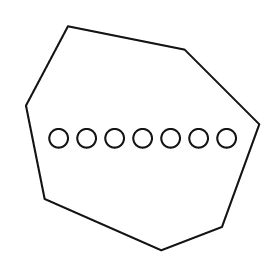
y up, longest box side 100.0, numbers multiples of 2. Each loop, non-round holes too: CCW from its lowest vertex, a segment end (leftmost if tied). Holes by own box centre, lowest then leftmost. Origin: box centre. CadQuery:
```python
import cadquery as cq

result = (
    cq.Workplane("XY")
    .moveTo(8.0, -48.0)
    .lineTo(34.0, -38.0)
    .lineTo(50.0, 6.0)
    .lineTo(18.0, 38.0)
    .lineTo(-32.0, 48.0)
    .lineTo(-50.0, 14.0)
    .lineTo(-42.0, -26.0)
    .close()
    .moveTo(-36.0, 0.0)
    .circle(4.0)
    .moveTo(-24.0, 0.0)
    .circle(4.0)
    .moveTo(-12.0, 0.0)
    .circle(4.0)
    .moveTo(0.0, 0.0)
    .circle(4.0)
    .moveTo(12.0, 0.0)
    .circle(4.0)
    .moveTo(24.0, 0.0)
    .circle(4.0)
    .moveTo(36.0, 0.0)
    .circle(4.0)
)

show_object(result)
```